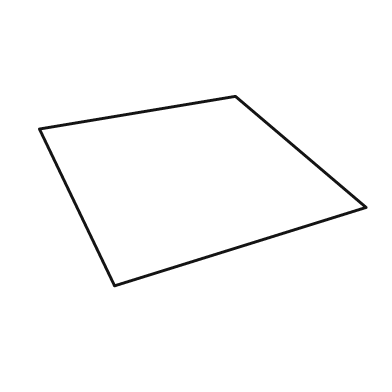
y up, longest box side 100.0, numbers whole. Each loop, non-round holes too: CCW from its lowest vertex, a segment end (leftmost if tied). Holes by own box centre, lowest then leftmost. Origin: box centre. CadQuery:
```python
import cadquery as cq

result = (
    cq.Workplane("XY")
    .moveTo(-27.0, -29.0)
    .lineTo(50.0, -5.0)
    .lineTo(10.0, 29.0)
    .lineTo(-50.0, 19.0)
    .close()
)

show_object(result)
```